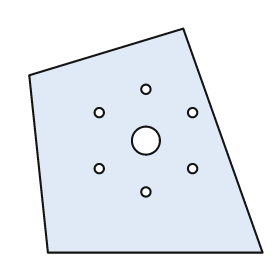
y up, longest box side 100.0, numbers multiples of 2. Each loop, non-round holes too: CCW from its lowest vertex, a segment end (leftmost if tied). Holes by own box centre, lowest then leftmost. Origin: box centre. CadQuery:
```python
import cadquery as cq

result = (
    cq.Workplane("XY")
    .moveTo(-42.0, -48.0)
    .lineTo(50.0, -48.0)
    .lineTo(16.0, 48.0)
    .lineTo(-50.0, 28.0)
    .close()
    .moveTo(0.0, -22.0)
    .circle(2.0)
    .moveTo(-20.0, -12.0)
    .circle(2.0)
    .moveTo(20.0, -12.0)
    .circle(2.0)
    .moveTo(0.0, 0.0)
    .circle(6.0)
    .moveTo(-20.0, 12.0)
    .circle(2.0)
    .moveTo(20.0, 12.0)
    .circle(2.0)
    .moveTo(0.0, 22.0)
    .circle(2.0)
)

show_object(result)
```